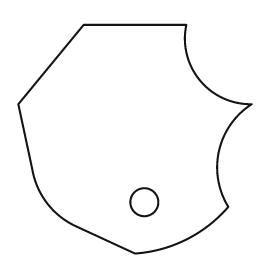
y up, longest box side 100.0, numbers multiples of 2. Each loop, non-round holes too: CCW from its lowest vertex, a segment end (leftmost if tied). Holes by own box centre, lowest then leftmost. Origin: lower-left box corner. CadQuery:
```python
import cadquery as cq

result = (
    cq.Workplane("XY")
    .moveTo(50.0, 0.0)
    .threePointArc((72.0, 6.0), (90.0, 20.0))
    .threePointArc((86.0, 44.0), (100.0, 64.0))
    .threePointArc((78.0, 74.0), (72.0, 98.0))
    .lineTo(28.0, 98.0)
    .lineTo(0.0, 64.0)
    .lineTo(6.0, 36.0)
    .threePointArc((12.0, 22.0), (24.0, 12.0))
    .close()
    .moveTo(54.0, 22.0)
    .circle(6.0)
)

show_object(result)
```